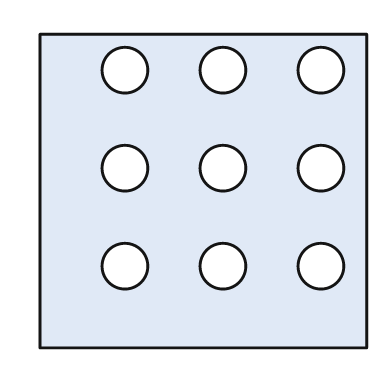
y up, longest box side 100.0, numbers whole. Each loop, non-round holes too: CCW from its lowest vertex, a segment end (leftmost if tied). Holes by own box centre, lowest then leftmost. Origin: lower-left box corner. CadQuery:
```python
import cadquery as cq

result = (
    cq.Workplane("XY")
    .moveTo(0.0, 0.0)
    .lineTo(100.0, 0.0)
    .lineTo(100.0, 96.0)
    .lineTo(0.0, 96.0)
    .close()
    .moveTo(26.0, 25.0)
    .circle(7.0)
    .moveTo(56.0, 25.0)
    .circle(7.0)
    .moveTo(86.0, 25.0)
    .circle(7.0)
    .moveTo(26.0, 55.0)
    .circle(7.0)
    .moveTo(56.0, 55.0)
    .circle(7.0)
    .moveTo(86.0, 55.0)
    .circle(7.0)
    .moveTo(26.0, 85.0)
    .circle(7.0)
    .moveTo(56.0, 85.0)
    .circle(7.0)
    .moveTo(86.0, 85.0)
    .circle(7.0)
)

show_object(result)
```